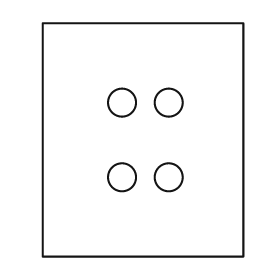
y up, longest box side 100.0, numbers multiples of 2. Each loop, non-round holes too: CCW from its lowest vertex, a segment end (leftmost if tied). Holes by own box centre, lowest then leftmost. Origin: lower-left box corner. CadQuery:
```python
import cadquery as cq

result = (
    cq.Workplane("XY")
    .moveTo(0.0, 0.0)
    .lineTo(86.0, 0.0)
    .lineTo(86.0, 100.0)
    .lineTo(0.0, 100.0)
    .close()
    .moveTo(34.0, 34.0)
    .circle(6.0)
    .moveTo(54.0, 34.0)
    .circle(6.0)
    .moveTo(34.0, 66.0)
    .circle(6.0)
    .moveTo(54.0, 66.0)
    .circle(6.0)
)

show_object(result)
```